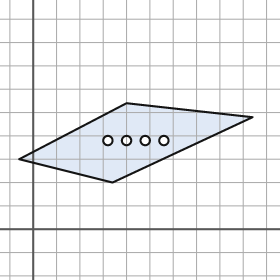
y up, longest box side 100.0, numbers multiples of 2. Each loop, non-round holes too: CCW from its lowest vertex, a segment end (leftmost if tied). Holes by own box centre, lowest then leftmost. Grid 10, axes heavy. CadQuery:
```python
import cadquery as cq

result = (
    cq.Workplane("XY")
    .moveTo(34.0, 20.0)
    .lineTo(94.0, 48.0)
    .lineTo(40.0, 54.0)
    .lineTo(-6.0, 30.0)
    .close()
    .moveTo(32.0, 38.0)
    .circle(2.0)
    .moveTo(40.0, 38.0)
    .circle(2.0)
    .moveTo(48.0, 38.0)
    .circle(2.0)
    .moveTo(56.0, 38.0)
    .circle(2.0)
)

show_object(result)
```